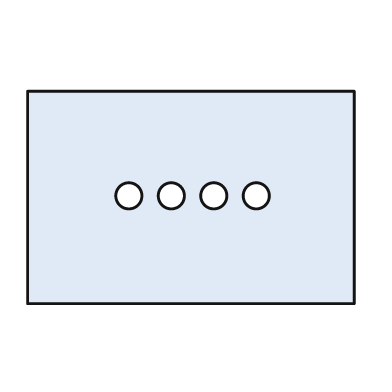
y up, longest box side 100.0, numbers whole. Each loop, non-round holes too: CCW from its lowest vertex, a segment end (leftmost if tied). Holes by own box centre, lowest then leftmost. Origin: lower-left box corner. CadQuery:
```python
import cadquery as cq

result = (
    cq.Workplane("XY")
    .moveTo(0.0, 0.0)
    .lineTo(100.0, 0.0)
    .lineTo(100.0, 65.0)
    .lineTo(0.0, 65.0)
    .close()
    .moveTo(31.0, 33.0)
    .circle(4.0)
    .moveTo(44.0, 33.0)
    .circle(4.0)
    .moveTo(57.0, 33.0)
    .circle(4.0)
    .moveTo(70.0, 33.0)
    .circle(4.0)
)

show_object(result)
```